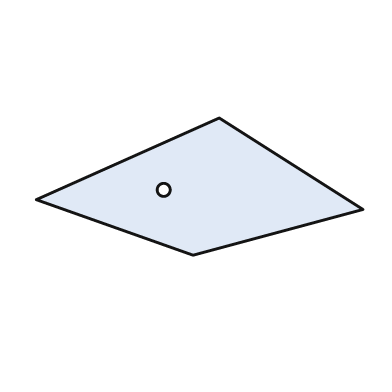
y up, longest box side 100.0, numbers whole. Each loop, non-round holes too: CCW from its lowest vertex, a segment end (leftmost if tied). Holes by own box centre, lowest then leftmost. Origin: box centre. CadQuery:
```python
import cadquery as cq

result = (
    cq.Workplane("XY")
    .moveTo(-2.0, -21.0)
    .lineTo(50.0, -7.0)
    .lineTo(6.0, 21.0)
    .lineTo(-50.0, -4.0)
    .close()
    .moveTo(-11.0, -1.0)
    .circle(2.0)
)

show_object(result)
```